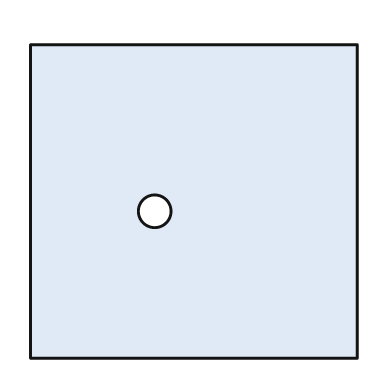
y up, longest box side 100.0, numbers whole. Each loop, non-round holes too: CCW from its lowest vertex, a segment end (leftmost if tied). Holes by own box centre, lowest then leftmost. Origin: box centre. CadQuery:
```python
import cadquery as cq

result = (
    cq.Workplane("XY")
    .moveTo(-50.0, -48.0)
    .lineTo(50.0, -48.0)
    .lineTo(50.0, 48.0)
    .lineTo(-50.0, 48.0)
    .close()
    .moveTo(-12.0, -3.0)
    .circle(5.0)
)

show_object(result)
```